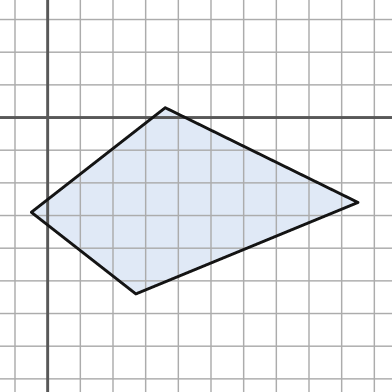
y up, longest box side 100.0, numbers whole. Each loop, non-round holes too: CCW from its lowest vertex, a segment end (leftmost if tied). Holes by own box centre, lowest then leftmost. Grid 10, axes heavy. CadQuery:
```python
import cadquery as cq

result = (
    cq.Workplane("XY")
    .moveTo(27.0, -54.0)
    .lineTo(95.0, -26.0)
    .lineTo(36.0, 3.0)
    .lineTo(-5.0, -29.0)
    .close()
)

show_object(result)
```